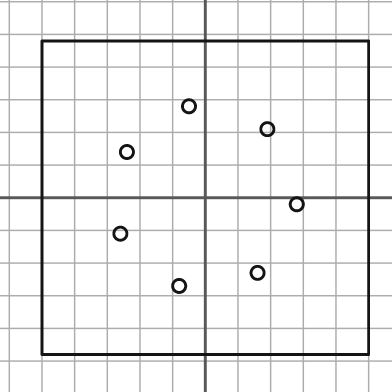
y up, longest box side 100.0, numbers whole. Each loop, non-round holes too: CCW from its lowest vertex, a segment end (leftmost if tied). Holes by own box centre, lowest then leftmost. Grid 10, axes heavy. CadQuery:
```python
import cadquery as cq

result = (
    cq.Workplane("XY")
    .moveTo(-50.0, -48.0)
    .lineTo(50.0, -48.0)
    .lineTo(50.0, 48.0)
    .lineTo(-50.0, 48.0)
    .close()
    .moveTo(-8.0, -27.0)
    .circle(2.0)
    .moveTo(16.0, -23.0)
    .circle(2.0)
    .moveTo(-26.0, -11.0)
    .circle(2.0)
    .moveTo(28.0, -2.0)
    .circle(2.0)
    .moveTo(-24.0, 14.0)
    .circle(2.0)
    .moveTo(19.0, 21.0)
    .circle(2.0)
    .moveTo(-5.0, 28.0)
    .circle(2.0)
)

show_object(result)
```